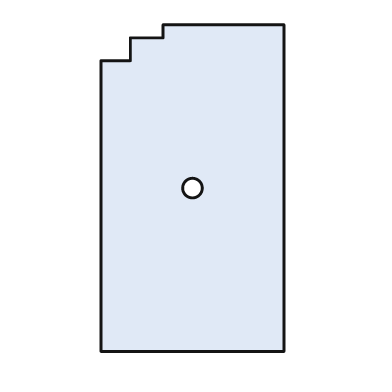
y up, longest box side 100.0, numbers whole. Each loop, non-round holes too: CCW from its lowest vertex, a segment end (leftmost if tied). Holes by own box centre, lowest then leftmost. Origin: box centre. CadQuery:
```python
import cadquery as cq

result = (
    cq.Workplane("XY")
    .moveTo(-28.0, -50.0)
    .lineTo(28.0, -50.0)
    .lineTo(28.0, 50.0)
    .lineTo(-9.0, 50.0)
    .lineTo(-9.0, 46.0)
    .lineTo(-19.0, 46.0)
    .lineTo(-19.0, 39.0)
    .lineTo(-28.0, 39.0)
    .close()
    .moveTo(0.0, 0.0)
    .circle(3.0)
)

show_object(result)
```